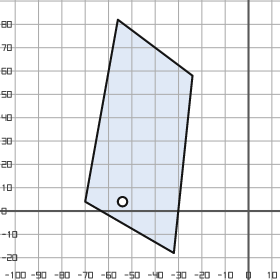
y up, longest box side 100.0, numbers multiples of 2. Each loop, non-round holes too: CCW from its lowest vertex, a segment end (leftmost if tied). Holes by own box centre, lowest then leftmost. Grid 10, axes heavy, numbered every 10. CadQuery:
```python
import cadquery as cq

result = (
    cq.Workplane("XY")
    .moveTo(-32.0, -18.0)
    .lineTo(-24.0, 58.0)
    .lineTo(-56.0, 82.0)
    .lineTo(-70.0, 4.0)
    .close()
    .moveTo(-54.0, 4.0)
    .circle(2.0)
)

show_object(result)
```